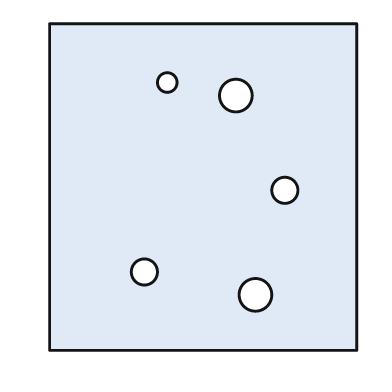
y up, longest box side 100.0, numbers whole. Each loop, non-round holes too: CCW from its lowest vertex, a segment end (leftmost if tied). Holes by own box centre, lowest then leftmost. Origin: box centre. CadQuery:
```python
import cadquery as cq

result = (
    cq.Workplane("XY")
    .moveTo(-47.0, -50.0)
    .lineTo(47.0, -50.0)
    .lineTo(47.0, 50.0)
    .lineTo(-47.0, 50.0)
    .close()
    .moveTo(16.0, -33.0)
    .circle(5.0)
    .moveTo(-18.0, -26.0)
    .circle(4.0)
    .moveTo(25.0, -1.0)
    .circle(4.0)
    .moveTo(10.0, 28.0)
    .circle(5.0)
    .moveTo(-11.0, 32.0)
    .circle(3.0)
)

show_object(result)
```